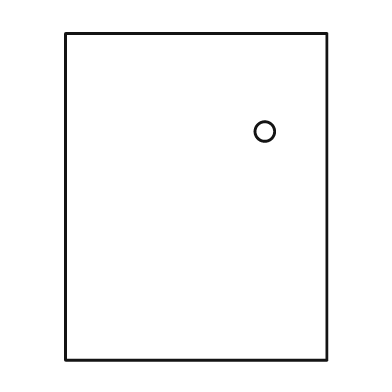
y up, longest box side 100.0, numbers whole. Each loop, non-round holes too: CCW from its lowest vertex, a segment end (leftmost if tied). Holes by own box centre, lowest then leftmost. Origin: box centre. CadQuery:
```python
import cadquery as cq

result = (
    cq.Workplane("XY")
    .moveTo(-40.0, -50.0)
    .lineTo(40.0, -50.0)
    .lineTo(40.0, 50.0)
    .lineTo(-40.0, 50.0)
    .close()
    .moveTo(21.0, 20.0)
    .circle(3.0)
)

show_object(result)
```